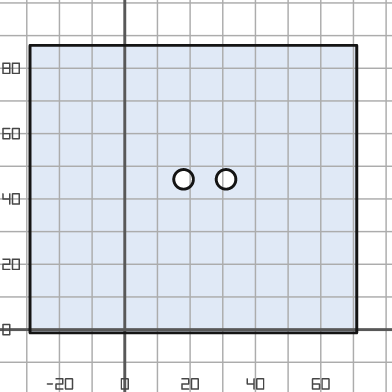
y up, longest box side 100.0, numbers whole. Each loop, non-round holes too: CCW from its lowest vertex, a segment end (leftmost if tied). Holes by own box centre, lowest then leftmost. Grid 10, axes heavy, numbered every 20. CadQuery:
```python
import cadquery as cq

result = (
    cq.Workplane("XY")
    .moveTo(-29.0, -1.0)
    .lineTo(71.0, -1.0)
    .lineTo(71.0, 87.0)
    .lineTo(-29.0, 87.0)
    .close()
    .moveTo(18.0, 46.0)
    .circle(3.0)
    .moveTo(31.0, 46.0)
    .circle(3.0)
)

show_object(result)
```